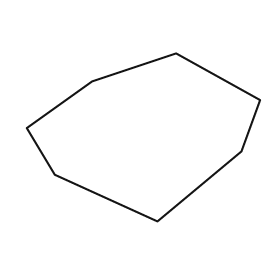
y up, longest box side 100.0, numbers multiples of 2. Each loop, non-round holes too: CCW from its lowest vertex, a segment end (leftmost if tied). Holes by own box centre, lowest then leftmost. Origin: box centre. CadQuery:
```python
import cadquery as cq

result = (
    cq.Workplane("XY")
    .moveTo(6.0, -36.0)
    .lineTo(42.0, -6.0)
    .lineTo(50.0, 16.0)
    .lineTo(14.0, 36.0)
    .lineTo(-22.0, 24.0)
    .lineTo(-50.0, 4.0)
    .lineTo(-38.0, -16.0)
    .close()
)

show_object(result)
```